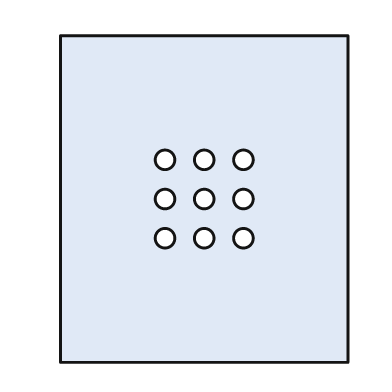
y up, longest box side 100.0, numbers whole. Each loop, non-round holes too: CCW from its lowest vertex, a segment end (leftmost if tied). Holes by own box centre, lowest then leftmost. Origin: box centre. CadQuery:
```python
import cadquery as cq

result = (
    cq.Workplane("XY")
    .moveTo(-44.0, -50.0)
    .lineTo(44.0, -50.0)
    .lineTo(44.0, 50.0)
    .lineTo(-44.0, 50.0)
    .close()
    .moveTo(-12.0, -12.0)
    .circle(3.0)
    .moveTo(0.0, -12.0)
    .circle(3.0)
    .moveTo(12.0, -12.0)
    .circle(3.0)
    .moveTo(-12.0, 0.0)
    .circle(3.0)
    .moveTo(0.0, 0.0)
    .circle(3.0)
    .moveTo(12.0, 0.0)
    .circle(3.0)
    .moveTo(-12.0, 12.0)
    .circle(3.0)
    .moveTo(0.0, 12.0)
    .circle(3.0)
    .moveTo(12.0, 12.0)
    .circle(3.0)
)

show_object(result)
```